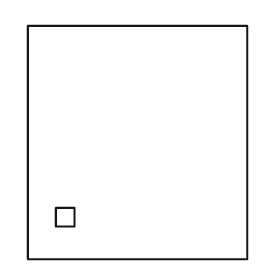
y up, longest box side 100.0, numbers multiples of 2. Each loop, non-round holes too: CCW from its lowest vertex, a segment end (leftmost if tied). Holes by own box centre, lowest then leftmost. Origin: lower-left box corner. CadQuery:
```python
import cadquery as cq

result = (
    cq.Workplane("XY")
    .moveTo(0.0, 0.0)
    .lineTo(94.0, 0.0)
    .lineTo(94.0, 100.0)
    .lineTo(0.0, 100.0)
    .close()
    .moveTo(12.0, 14.0)
    .lineTo(20.0, 14.0)
    .lineTo(20.0, 22.0)
    .lineTo(12.0, 22.0)
    .close()
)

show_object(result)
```